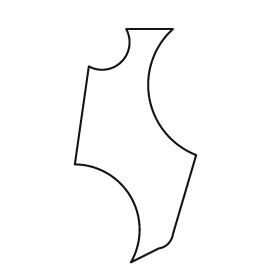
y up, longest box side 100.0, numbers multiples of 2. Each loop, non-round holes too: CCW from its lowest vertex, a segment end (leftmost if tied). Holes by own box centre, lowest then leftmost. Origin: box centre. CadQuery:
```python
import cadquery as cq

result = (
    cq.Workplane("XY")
    .moveTo(-2.0, -50.0)
    .lineTo(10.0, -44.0)
    .threePointArc((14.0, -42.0), (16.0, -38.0))
    .lineTo(26.0, -4.0)
    .threePointArc((6.0, 20.0), (16.0, 50.0))
    .lineTo(-4.0, 50.0)
    .threePointArc((-6.0, 36.0), (-20.0, 34.0))
    .lineTo(-26.0, -8.0)
    .threePointArc((-2.0, -22.0), (-2.0, -50.0))
    .close()
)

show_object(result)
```